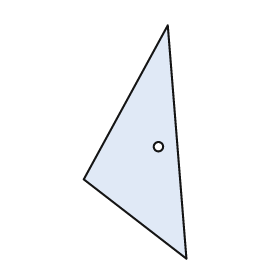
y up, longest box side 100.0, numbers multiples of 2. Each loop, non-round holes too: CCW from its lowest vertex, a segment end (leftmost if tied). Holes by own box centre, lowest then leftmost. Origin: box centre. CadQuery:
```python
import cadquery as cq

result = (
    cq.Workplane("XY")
    .moveTo(22.0, -50.0)
    .lineTo(14.0, 50.0)
    .lineTo(-22.0, -16.0)
    .close()
    .moveTo(10.0, -2.0)
    .circle(2.0)
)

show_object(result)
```